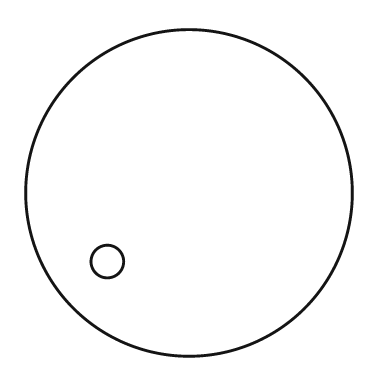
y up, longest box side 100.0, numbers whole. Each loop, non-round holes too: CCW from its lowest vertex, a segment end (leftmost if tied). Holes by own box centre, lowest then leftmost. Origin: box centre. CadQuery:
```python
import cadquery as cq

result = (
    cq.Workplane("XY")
    .moveTo(0.0, 0.0)
    .circle(50.0)
    .moveTo(-25.0, -21.0)
    .circle(5.0)
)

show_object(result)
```